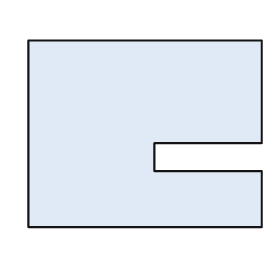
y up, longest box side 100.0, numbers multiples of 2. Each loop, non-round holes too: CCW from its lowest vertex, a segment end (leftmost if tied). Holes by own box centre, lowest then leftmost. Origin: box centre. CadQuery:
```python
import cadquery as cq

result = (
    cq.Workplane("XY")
    .moveTo(-50.0, -40.0)
    .lineTo(50.0, -40.0)
    .lineTo(50.0, -16.0)
    .lineTo(4.0, -16.0)
    .lineTo(4.0, -4.0)
    .lineTo(50.0, -4.0)
    .lineTo(50.0, 40.0)
    .lineTo(-50.0, 40.0)
    .close()
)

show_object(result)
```